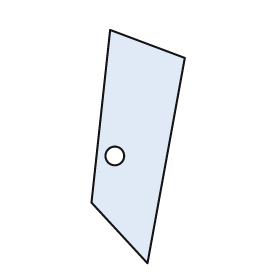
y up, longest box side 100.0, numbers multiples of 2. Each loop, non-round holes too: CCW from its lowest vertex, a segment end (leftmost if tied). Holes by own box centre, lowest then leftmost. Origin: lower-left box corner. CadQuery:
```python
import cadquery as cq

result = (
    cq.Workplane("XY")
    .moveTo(24.0, 0.0)
    .lineTo(40.0, 88.0)
    .lineTo(8.0, 100.0)
    .lineTo(0.0, 26.0)
    .close()
    .moveTo(10.0, 46.0)
    .circle(4.0)
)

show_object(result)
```